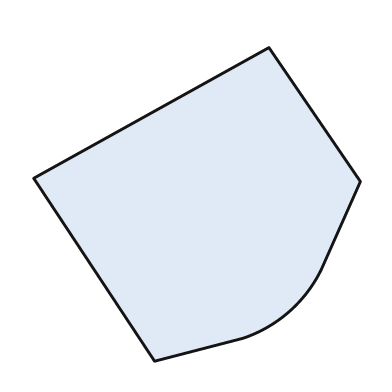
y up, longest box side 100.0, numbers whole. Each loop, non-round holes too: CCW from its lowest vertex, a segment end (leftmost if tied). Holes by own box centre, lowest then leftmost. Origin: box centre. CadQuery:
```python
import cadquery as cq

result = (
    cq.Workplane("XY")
    .moveTo(-13.0, -48.0)
    .lineTo(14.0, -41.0)
    .threePointArc((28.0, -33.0), (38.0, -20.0))
    .lineTo(50.0, 7.0)
    .lineTo(22.0, 48.0)
    .lineTo(-50.0, 8.0)
    .close()
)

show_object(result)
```